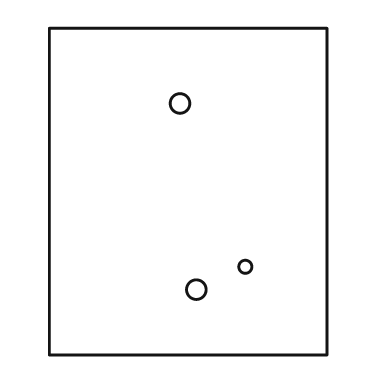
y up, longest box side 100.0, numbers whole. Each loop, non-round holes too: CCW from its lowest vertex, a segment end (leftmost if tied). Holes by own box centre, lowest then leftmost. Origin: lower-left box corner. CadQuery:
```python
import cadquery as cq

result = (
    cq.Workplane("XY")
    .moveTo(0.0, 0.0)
    .lineTo(85.0, 0.0)
    .lineTo(85.0, 100.0)
    .lineTo(0.0, 100.0)
    .close()
    .moveTo(45.0, 20.0)
    .circle(3.0)
    .moveTo(60.0, 27.0)
    .circle(2.0)
    .moveTo(40.0, 77.0)
    .circle(3.0)
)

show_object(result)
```